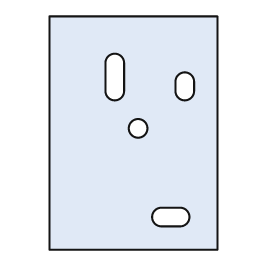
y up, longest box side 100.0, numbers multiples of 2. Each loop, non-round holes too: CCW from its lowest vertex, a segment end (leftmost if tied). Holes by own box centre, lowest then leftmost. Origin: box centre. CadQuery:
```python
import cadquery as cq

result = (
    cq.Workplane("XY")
    .moveTo(-36.0, -50.0)
    .lineTo(36.0, -50.0)
    .lineTo(36.0, 50.0)
    .lineTo(-36.0, 50.0)
    .close()
    .moveTo(12.0, -40.0)
    .lineTo(20.0, -40.0)
    .threePointArc((24.0, -36.0), (20.0, -32.0))
    .lineTo(12.0, -32.0)
    .threePointArc((8.0, -36.0), (12.0, -40.0))
    .close()
    .moveTo(2.0, 2.0)
    .circle(4.0)
    .moveTo(18.0, 18.0)
    .threePointArc((22.0, 14.0), (26.0, 18.0))
    .lineTo(26.0, 22.0)
    .threePointArc((22.0, 26.0), (18.0, 22.0))
    .close()
    .moveTo(-12.0, 18.0)
    .threePointArc((-8.0, 14.0), (-4.0, 18.0))
    .lineTo(-4.0, 30.0)
    .threePointArc((-8.0, 34.0), (-12.0, 30.0))
    .close()
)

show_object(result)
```